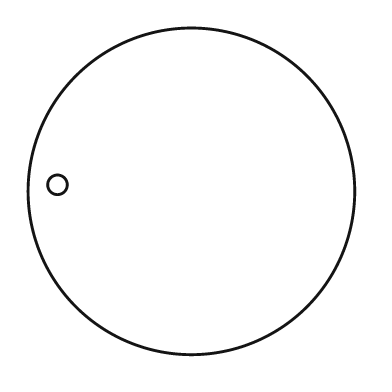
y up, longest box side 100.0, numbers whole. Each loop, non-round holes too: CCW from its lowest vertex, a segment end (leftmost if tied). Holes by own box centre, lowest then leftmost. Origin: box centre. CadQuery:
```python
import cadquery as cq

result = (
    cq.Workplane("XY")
    .moveTo(0.0, 0.0)
    .circle(50.0)
    .moveTo(-41.0, 2.0)
    .circle(3.0)
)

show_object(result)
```